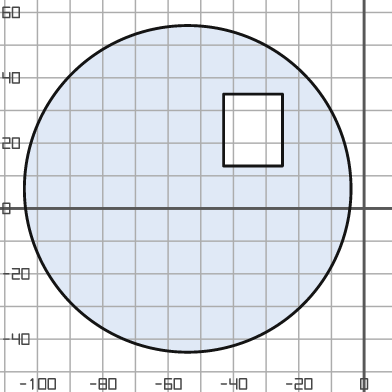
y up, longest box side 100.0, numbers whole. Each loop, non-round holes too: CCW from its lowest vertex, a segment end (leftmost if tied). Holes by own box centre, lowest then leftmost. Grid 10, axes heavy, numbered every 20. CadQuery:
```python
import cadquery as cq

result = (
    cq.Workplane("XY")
    .moveTo(-54.0, 6.0)
    .circle(50.0)
    .moveTo(-43.0, 13.0)
    .lineTo(-25.0, 13.0)
    .lineTo(-25.0, 35.0)
    .lineTo(-43.0, 35.0)
    .close()
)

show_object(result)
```